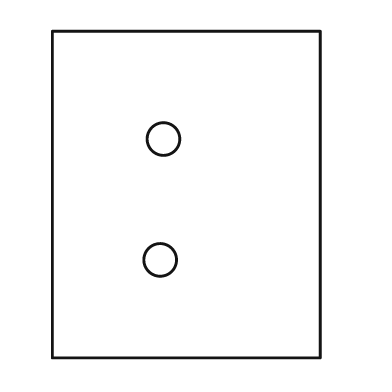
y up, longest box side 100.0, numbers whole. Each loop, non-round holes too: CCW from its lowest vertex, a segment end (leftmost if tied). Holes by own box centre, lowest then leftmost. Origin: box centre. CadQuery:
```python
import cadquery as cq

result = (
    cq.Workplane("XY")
    .moveTo(-41.0, -50.0)
    .lineTo(41.0, -50.0)
    .lineTo(41.0, 50.0)
    .lineTo(-41.0, 50.0)
    .close()
    .moveTo(-8.0, -20.0)
    .circle(5.0)
    .moveTo(-7.0, 17.0)
    .circle(5.0)
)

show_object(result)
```